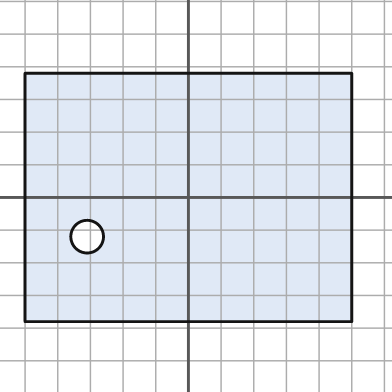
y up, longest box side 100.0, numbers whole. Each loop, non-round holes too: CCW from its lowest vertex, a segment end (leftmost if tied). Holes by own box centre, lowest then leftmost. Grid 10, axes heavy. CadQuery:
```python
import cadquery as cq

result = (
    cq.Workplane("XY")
    .moveTo(-50.0, -38.0)
    .lineTo(50.0, -38.0)
    .lineTo(50.0, 38.0)
    .lineTo(-50.0, 38.0)
    .close()
    .moveTo(-31.0, -12.0)
    .circle(5.0)
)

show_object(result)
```